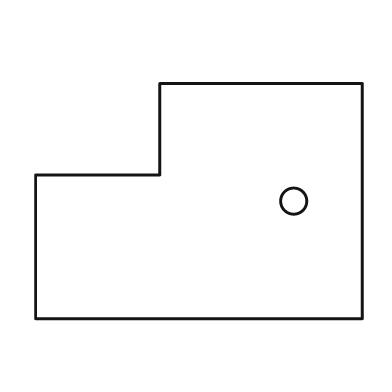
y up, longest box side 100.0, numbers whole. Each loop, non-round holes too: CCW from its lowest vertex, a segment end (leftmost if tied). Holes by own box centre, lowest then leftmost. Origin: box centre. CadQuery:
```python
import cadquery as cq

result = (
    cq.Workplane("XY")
    .moveTo(-50.0, -36.0)
    .lineTo(50.0, -36.0)
    .lineTo(50.0, 36.0)
    .lineTo(-12.0, 36.0)
    .lineTo(-12.0, 8.0)
    .lineTo(-50.0, 8.0)
    .close()
    .moveTo(29.0, 0.0)
    .circle(4.0)
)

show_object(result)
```